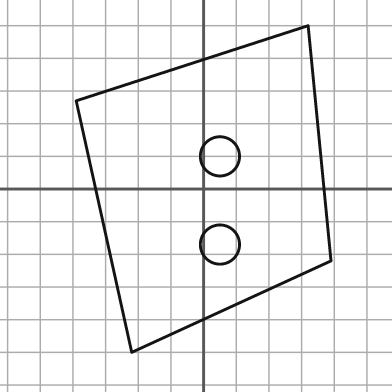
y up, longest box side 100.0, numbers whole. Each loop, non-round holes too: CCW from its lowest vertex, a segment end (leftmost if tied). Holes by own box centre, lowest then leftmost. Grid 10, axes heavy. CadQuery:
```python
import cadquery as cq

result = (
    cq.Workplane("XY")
    .moveTo(-22.0, -50.0)
    .lineTo(39.0, -22.0)
    .lineTo(32.0, 50.0)
    .lineTo(-39.0, 27.0)
    .close()
    .moveTo(5.0, -17.0)
    .circle(6.0)
    .moveTo(5.0, 10.0)
    .circle(6.0)
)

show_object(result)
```